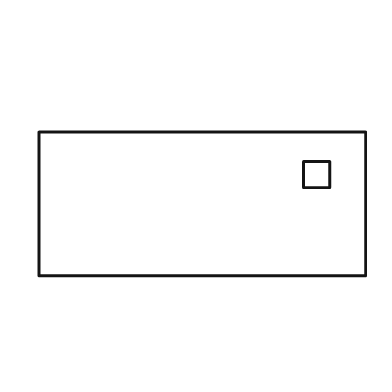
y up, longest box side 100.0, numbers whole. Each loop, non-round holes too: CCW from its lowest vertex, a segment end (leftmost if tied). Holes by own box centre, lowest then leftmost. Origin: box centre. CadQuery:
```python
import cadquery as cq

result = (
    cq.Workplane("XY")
    .moveTo(-50.0, -22.0)
    .lineTo(50.0, -22.0)
    .lineTo(50.0, 22.0)
    .lineTo(-50.0, 22.0)
    .close()
    .moveTo(31.0, 5.0)
    .lineTo(39.0, 5.0)
    .lineTo(39.0, 13.0)
    .lineTo(31.0, 13.0)
    .close()
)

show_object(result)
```